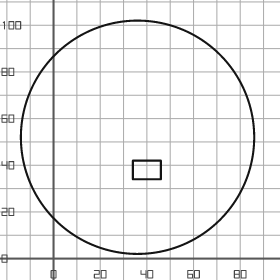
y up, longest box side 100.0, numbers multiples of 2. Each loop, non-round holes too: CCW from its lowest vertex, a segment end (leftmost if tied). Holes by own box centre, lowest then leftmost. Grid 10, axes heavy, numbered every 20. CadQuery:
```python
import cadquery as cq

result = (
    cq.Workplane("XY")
    .moveTo(36.0, 52.0)
    .circle(50.0)
    .moveTo(34.0, 34.0)
    .lineTo(46.0, 34.0)
    .lineTo(46.0, 42.0)
    .lineTo(34.0, 42.0)
    .close()
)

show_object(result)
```